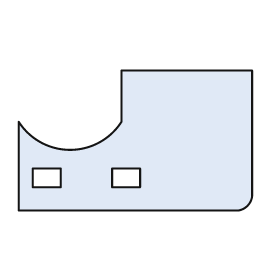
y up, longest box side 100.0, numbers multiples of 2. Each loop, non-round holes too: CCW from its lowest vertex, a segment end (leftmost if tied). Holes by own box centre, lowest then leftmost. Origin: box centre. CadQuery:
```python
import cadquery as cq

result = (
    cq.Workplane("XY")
    .moveTo(-50.0, -30.0)
    .lineTo(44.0, -30.0)
    .threePointArc((48.0, -28.0), (50.0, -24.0))
    .lineTo(50.0, 30.0)
    .lineTo(-6.0, 30.0)
    .lineTo(-6.0, 8.0)
    .threePointArc((-28.0, -4.0), (-50.0, 8.0))
    .close()
    .moveTo(-44.0, -20.0)
    .lineTo(-32.0, -20.0)
    .lineTo(-32.0, -12.0)
    .lineTo(-44.0, -12.0)
    .close()
    .moveTo(-10.0, -20.0)
    .lineTo(2.0, -20.0)
    .lineTo(2.0, -12.0)
    .lineTo(-10.0, -12.0)
    .close()
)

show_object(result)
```